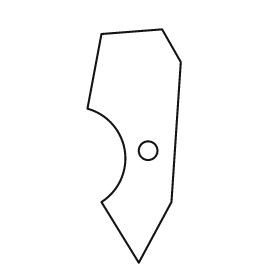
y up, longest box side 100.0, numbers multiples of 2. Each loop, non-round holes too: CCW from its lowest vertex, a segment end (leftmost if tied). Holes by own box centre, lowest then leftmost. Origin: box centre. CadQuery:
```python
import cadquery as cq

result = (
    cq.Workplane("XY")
    .moveTo(2.0, -50.0)
    .lineTo(16.0, -24.0)
    .lineTo(20.0, 36.0)
    .lineTo(12.0, 50.0)
    .lineTo(-14.0, 48.0)
    .lineTo(-20.0, 16.0)
    .threePointArc((-4.0, -2.0), (-14.0, -24.0))
    .close()
    .moveTo(6.0, -2.0)
    .circle(4.0)
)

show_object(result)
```